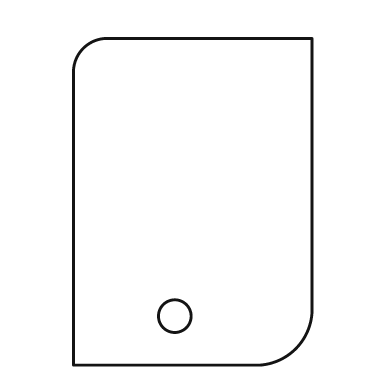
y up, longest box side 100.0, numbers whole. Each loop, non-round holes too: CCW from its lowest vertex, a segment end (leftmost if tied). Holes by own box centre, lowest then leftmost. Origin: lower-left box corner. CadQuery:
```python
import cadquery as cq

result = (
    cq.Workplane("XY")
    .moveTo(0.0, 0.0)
    .lineTo(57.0, 0.0)
    .threePointArc((68.0, 5.0), (73.0, 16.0))
    .lineTo(73.0, 100.0)
    .lineTo(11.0, 100.0)
    .threePointArc((3.0, 97.0), (0.0, 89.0))
    .close()
    .moveTo(31.0, 15.0)
    .circle(5.0)
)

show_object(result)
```